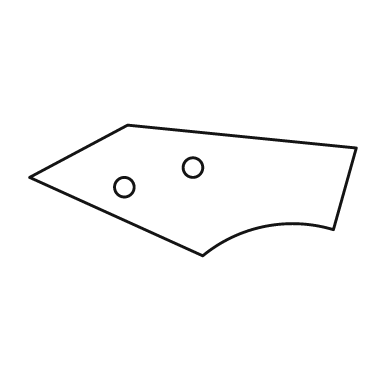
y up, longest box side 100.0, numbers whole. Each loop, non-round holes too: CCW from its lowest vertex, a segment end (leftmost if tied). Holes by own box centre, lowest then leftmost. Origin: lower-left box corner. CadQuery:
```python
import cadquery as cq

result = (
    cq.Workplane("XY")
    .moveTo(53.0, 0.0)
    .threePointArc((72.0, 9.0), (93.0, 8.0))
    .lineTo(100.0, 33.0)
    .lineTo(30.0, 40.0)
    .lineTo(0.0, 24.0)
    .close()
    .moveTo(29.0, 21.0)
    .circle(3.0)
    .moveTo(50.0, 27.0)
    .circle(3.0)
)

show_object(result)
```